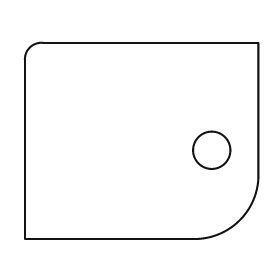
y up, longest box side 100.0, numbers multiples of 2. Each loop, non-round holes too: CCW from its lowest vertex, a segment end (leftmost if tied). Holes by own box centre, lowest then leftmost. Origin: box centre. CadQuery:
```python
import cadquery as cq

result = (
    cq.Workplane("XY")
    .moveTo(-50.0, -42.0)
    .lineTo(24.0, -42.0)
    .threePointArc((42.0, -34.0), (50.0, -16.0))
    .lineTo(50.0, 42.0)
    .lineTo(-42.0, 42.0)
    .threePointArc((-48.0, 40.0), (-50.0, 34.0))
    .close()
    .moveTo(30.0, -4.0)
    .circle(8.0)
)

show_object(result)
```